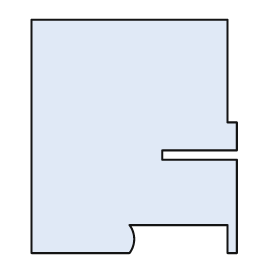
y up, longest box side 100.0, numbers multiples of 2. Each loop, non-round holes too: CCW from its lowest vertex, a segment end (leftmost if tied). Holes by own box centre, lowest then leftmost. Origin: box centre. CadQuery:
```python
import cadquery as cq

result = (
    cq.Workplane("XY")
    .moveTo(-44.0, -50.0)
    .lineTo(-2.0, -50.0)
    .threePointArc((0.0, -44.0), (-2.0, -38.0))
    .lineTo(40.0, -38.0)
    .lineTo(40.0, -50.0)
    .lineTo(44.0, -50.0)
    .lineTo(44.0, -10.0)
    .lineTo(12.0, -10.0)
    .lineTo(12.0, -6.0)
    .lineTo(44.0, -6.0)
    .lineTo(44.0, 6.0)
    .lineTo(40.0, 6.0)
    .lineTo(40.0, 50.0)
    .lineTo(-44.0, 50.0)
    .close()
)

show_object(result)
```